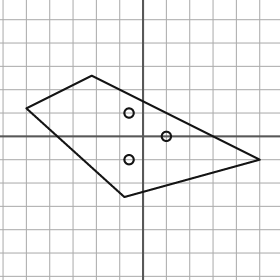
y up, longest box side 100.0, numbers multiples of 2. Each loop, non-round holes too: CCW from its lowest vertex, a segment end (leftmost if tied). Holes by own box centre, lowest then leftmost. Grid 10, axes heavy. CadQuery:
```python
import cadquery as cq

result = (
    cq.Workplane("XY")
    .moveTo(-8.0, -26.0)
    .lineTo(50.0, -10.0)
    .lineTo(-22.0, 26.0)
    .lineTo(-50.0, 12.0)
    .close()
    .moveTo(-6.0, -10.0)
    .circle(2.0)
    .moveTo(10.0, 0.0)
    .circle(2.0)
    .moveTo(-6.0, 10.0)
    .circle(2.0)
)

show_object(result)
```